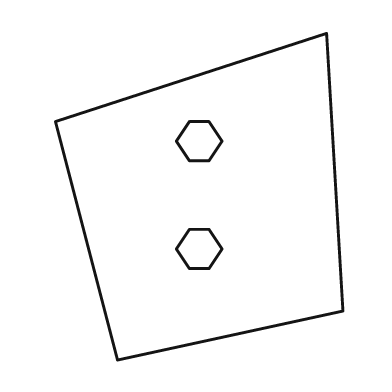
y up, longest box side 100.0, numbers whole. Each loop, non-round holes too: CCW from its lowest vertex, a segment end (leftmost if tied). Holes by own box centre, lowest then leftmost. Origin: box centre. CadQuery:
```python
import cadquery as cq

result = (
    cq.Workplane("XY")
    .moveTo(-25.0, -50.0)
    .lineTo(44.0, -35.0)
    .lineTo(39.0, 50.0)
    .lineTo(-44.0, 23.0)
    .close()
    .moveTo(-3.0, -22.0)
    .lineTo(3.0, -22.0)
    .lineTo(7.0, -16.0)
    .lineTo(3.0, -10.0)
    .lineTo(-3.0, -10.0)
    .lineTo(-7.0, -16.0)
    .close()
    .moveTo(-3.0, 11.0)
    .lineTo(3.0, 11.0)
    .lineTo(7.0, 17.0)
    .lineTo(3.0, 23.0)
    .lineTo(-3.0, 23.0)
    .lineTo(-7.0, 17.0)
    .close()
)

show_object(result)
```